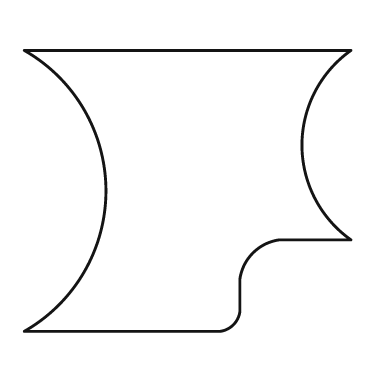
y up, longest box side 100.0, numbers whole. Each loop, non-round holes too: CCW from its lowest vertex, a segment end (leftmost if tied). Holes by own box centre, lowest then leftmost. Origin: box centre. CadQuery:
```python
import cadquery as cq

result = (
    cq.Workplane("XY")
    .moveTo(-50.0, -43.0)
    .lineTo(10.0, -43.0)
    .threePointArc((14.0, -41.0), (16.0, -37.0))
    .lineTo(16.0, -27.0)
    .threePointArc((20.0, -19.0), (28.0, -15.0))
    .lineTo(50.0, -15.0)
    .threePointArc((35.0, 14.0), (50.0, 43.0))
    .lineTo(-50.0, 43.0)
    .threePointArc((-25.0, 0.0), (-50.0, -43.0))
    .close()
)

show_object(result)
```